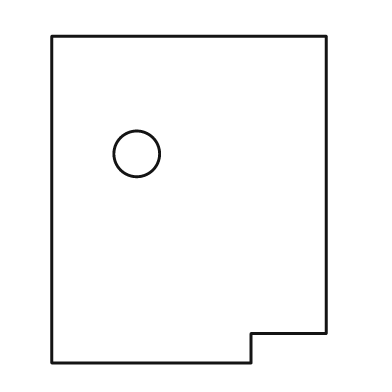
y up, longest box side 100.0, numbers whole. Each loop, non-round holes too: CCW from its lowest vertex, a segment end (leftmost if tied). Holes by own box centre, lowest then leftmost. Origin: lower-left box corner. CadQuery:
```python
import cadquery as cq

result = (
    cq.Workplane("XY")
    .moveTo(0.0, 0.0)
    .lineTo(61.0, 0.0)
    .lineTo(61.0, 9.0)
    .lineTo(84.0, 9.0)
    .lineTo(84.0, 100.0)
    .lineTo(0.0, 100.0)
    .close()
    .moveTo(26.0, 64.0)
    .circle(7.0)
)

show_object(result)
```